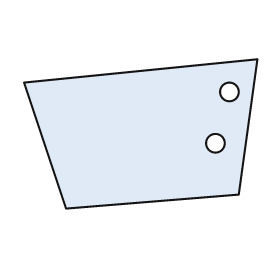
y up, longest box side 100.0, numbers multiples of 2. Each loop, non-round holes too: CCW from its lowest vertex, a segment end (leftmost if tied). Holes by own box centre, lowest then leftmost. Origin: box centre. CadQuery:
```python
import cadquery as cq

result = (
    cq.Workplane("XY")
    .moveTo(-32.0, -32.0)
    .lineTo(42.0, -26.0)
    .lineTo(50.0, 32.0)
    .lineTo(-50.0, 22.0)
    .close()
    .moveTo(32.0, -4.0)
    .circle(4.0)
    .moveTo(38.0, 18.0)
    .circle(4.0)
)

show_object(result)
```